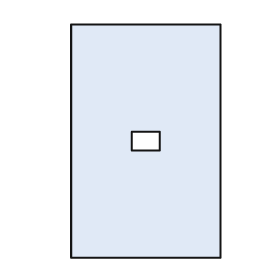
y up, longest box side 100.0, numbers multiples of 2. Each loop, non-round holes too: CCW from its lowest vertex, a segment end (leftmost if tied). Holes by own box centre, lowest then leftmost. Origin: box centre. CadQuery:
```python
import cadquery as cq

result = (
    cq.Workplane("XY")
    .moveTo(-32.0, -50.0)
    .lineTo(32.0, -50.0)
    .lineTo(32.0, 50.0)
    .lineTo(-32.0, 50.0)
    .close()
    .moveTo(-6.0, -4.0)
    .lineTo(6.0, -4.0)
    .lineTo(6.0, 4.0)
    .lineTo(-6.0, 4.0)
    .close()
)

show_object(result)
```